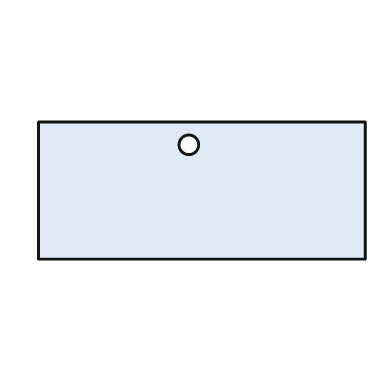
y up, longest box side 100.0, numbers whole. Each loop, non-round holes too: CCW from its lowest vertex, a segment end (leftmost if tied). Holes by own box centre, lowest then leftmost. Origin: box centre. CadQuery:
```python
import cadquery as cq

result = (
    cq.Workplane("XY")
    .moveTo(-50.0, -21.0)
    .lineTo(50.0, -21.0)
    .lineTo(50.0, 21.0)
    .lineTo(-50.0, 21.0)
    .close()
    .moveTo(-4.0, 14.0)
    .circle(3.0)
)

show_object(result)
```